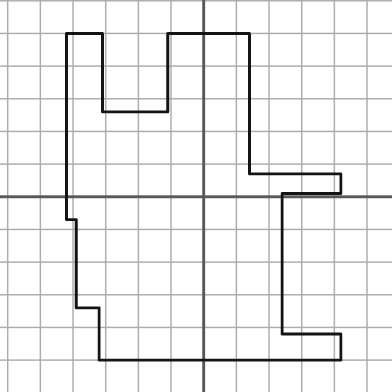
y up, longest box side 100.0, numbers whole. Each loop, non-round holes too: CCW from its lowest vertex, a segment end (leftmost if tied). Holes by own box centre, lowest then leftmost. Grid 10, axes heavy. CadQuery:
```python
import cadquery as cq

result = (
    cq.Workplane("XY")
    .moveTo(-32.0, -50.0)
    .lineTo(42.0, -50.0)
    .lineTo(42.0, -42.0)
    .lineTo(24.0, -42.0)
    .lineTo(24.0, 1.0)
    .lineTo(42.0, 1.0)
    .lineTo(42.0, 7.0)
    .lineTo(14.0, 7.0)
    .lineTo(14.0, 50.0)
    .lineTo(-11.0, 50.0)
    .lineTo(-11.0, 26.0)
    .lineTo(-31.0, 26.0)
    .lineTo(-31.0, 50.0)
    .lineTo(-42.0, 50.0)
    .lineTo(-42.0, -7.0)
    .lineTo(-39.0, -7.0)
    .lineTo(-39.0, -34.0)
    .lineTo(-32.0, -34.0)
    .close()
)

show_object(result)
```